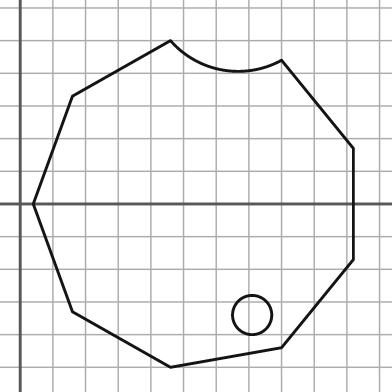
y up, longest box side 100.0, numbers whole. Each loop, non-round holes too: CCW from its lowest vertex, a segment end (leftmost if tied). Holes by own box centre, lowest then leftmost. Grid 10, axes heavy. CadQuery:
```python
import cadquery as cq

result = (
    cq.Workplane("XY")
    .moveTo(46.0, -50.0)
    .lineTo(80.0, -44.0)
    .lineTo(102.0, -17.0)
    .lineTo(102.0, 17.0)
    .lineTo(80.0, 44.0)
    .threePointArc((62.0, 41.0), (46.0, 50.0))
    .lineTo(16.0, 33.0)
    .lineTo(4.0, 0.0)
    .lineTo(16.0, -33.0)
    .close()
    .moveTo(71.0, -34.0)
    .circle(6.0)
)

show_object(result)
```